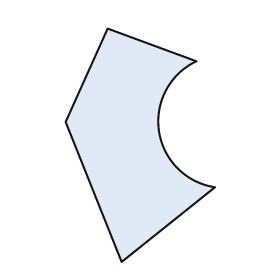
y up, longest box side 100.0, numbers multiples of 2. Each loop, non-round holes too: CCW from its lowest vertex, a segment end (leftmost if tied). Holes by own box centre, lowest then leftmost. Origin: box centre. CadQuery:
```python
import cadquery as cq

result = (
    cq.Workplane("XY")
    .moveTo(-8.0, -50.0)
    .lineTo(32.0, -18.0)
    .threePointArc((8.0, 6.0), (24.0, 36.0))
    .lineTo(-14.0, 50.0)
    .lineTo(-32.0, 10.0)
    .close()
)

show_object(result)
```